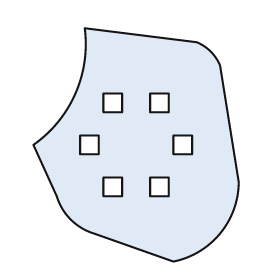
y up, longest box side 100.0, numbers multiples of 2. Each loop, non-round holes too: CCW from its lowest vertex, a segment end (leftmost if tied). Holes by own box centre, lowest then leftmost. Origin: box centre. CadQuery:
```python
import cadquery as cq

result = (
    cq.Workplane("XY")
    .moveTo(16.0, -50.0)
    .threePointArc((36.0, -38.0), (44.0, -16.0))
    .lineTo(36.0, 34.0)
    .threePointArc((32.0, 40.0), (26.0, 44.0))
    .lineTo(-22.0, 50.0)
    .threePointArc((-26.0, 22.0), (-44.0, 0.0))
    .lineTo(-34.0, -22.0)
    .threePointArc((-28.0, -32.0), (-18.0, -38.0))
    .close()
    .moveTo(-14.0, -22.0)
    .lineTo(-6.0, -22.0)
    .lineTo(-6.0, -14.0)
    .lineTo(-14.0, -14.0)
    .close()
    .moveTo(6.0, -22.0)
    .lineTo(14.0, -22.0)
    .lineTo(14.0, -14.0)
    .lineTo(6.0, -14.0)
    .close()
    .moveTo(-24.0, -4.0)
    .lineTo(-16.0, -4.0)
    .lineTo(-16.0, 4.0)
    .lineTo(-24.0, 4.0)
    .close()
    .moveTo(16.0, -4.0)
    .lineTo(24.0, -4.0)
    .lineTo(24.0, 4.0)
    .lineTo(16.0, 4.0)
    .close()
    .moveTo(-14.0, 14.0)
    .lineTo(-6.0, 14.0)
    .lineTo(-6.0, 22.0)
    .lineTo(-14.0, 22.0)
    .close()
    .moveTo(6.0, 14.0)
    .lineTo(14.0, 14.0)
    .lineTo(14.0, 22.0)
    .lineTo(6.0, 22.0)
    .close()
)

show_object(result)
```